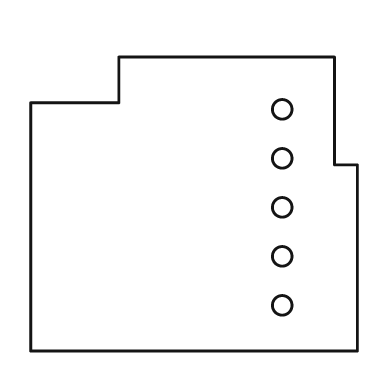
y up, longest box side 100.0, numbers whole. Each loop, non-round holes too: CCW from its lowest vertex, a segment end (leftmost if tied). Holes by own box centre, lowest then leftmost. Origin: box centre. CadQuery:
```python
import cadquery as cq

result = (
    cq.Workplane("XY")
    .moveTo(-50.0, -45.0)
    .lineTo(50.0, -45.0)
    .lineTo(50.0, 12.0)
    .lineTo(43.0, 12.0)
    .lineTo(43.0, 45.0)
    .lineTo(-23.0, 45.0)
    .lineTo(-23.0, 31.0)
    .lineTo(-50.0, 31.0)
    .close()
    .moveTo(27.0, -31.0)
    .circle(3.0)
    .moveTo(27.0, -16.0)
    .circle(3.0)
    .moveTo(27.0, -1.0)
    .circle(3.0)
    .moveTo(27.0, 14.0)
    .circle(3.0)
    .moveTo(27.0, 29.0)
    .circle(3.0)
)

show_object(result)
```